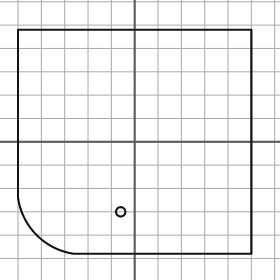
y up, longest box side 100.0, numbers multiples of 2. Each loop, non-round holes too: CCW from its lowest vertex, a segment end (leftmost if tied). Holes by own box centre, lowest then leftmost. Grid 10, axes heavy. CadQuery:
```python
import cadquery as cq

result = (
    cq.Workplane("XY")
    .moveTo(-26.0, -48.0)
    .lineTo(50.0, -48.0)
    .lineTo(50.0, 48.0)
    .lineTo(-50.0, 48.0)
    .lineTo(-50.0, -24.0)
    .threePointArc((-42.0, -40.0), (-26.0, -48.0))
    .close()
    .moveTo(-6.0, -30.0)
    .circle(2.0)
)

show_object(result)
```